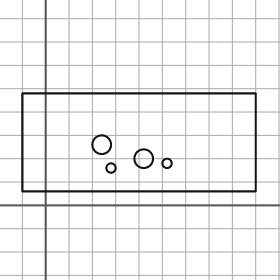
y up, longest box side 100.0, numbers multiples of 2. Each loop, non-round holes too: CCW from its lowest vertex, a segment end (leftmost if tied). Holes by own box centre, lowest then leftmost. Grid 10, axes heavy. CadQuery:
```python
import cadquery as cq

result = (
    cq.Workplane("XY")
    .moveTo(-10.0, 6.0)
    .lineTo(90.0, 6.0)
    .lineTo(90.0, 48.0)
    .lineTo(-10.0, 48.0)
    .close()
    .moveTo(28.0, 16.0)
    .circle(2.0)
    .moveTo(52.0, 18.0)
    .circle(2.0)
    .moveTo(42.0, 20.0)
    .circle(4.0)
    .moveTo(24.0, 26.0)
    .circle(4.0)
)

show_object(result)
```